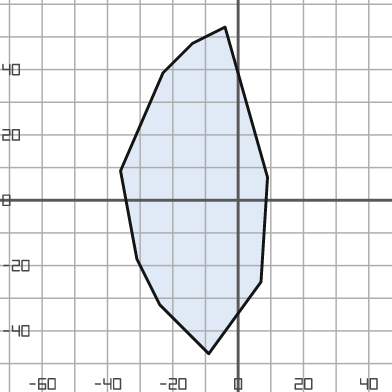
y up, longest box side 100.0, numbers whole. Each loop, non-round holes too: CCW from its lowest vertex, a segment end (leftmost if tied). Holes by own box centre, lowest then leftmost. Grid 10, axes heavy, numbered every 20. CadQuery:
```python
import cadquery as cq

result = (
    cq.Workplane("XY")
    .moveTo(-9.0, -47.0)
    .lineTo(7.0, -25.0)
    .lineTo(9.0, 7.0)
    .lineTo(-4.0, 53.0)
    .lineTo(-14.0, 48.0)
    .lineTo(-23.0, 39.0)
    .lineTo(-36.0, 9.0)
    .lineTo(-31.0, -18.0)
    .lineTo(-24.0, -32.0)
    .close()
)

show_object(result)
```